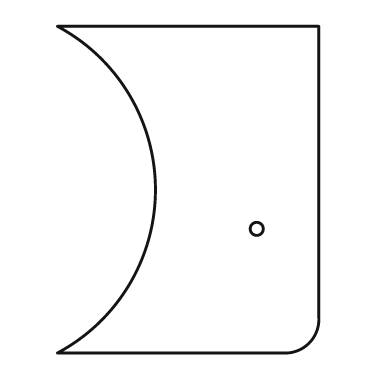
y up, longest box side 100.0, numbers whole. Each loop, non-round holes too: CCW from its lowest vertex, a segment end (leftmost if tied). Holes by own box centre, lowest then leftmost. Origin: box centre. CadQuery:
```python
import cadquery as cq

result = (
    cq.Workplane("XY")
    .moveTo(-40.0, -50.0)
    .lineTo(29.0, -50.0)
    .threePointArc((37.0, -47.0), (40.0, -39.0))
    .lineTo(40.0, 50.0)
    .lineTo(-40.0, 50.0)
    .threePointArc((-10.0, 0.0), (-40.0, -50.0))
    .close()
    .moveTo(21.0, -12.0)
    .circle(2.0)
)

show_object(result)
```